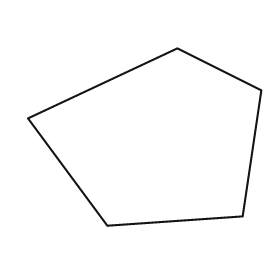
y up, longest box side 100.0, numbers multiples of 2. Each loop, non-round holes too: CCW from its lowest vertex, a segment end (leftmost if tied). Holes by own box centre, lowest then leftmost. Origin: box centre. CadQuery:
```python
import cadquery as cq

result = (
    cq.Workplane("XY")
    .moveTo(-16.0, -38.0)
    .lineTo(42.0, -34.0)
    .lineTo(50.0, 20.0)
    .lineTo(14.0, 38.0)
    .lineTo(-50.0, 8.0)
    .close()
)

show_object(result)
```